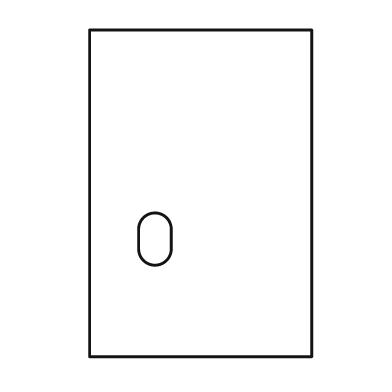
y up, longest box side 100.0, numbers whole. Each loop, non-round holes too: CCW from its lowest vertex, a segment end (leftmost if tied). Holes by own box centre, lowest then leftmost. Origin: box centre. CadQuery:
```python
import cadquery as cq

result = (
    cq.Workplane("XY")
    .moveTo(-34.0, -50.0)
    .lineTo(34.0, -50.0)
    .lineTo(34.0, 50.0)
    .lineTo(-34.0, 50.0)
    .close()
    .moveTo(-19.0, -17.0)
    .threePointArc((-14.0, -22.0), (-9.0, -17.0))
    .lineTo(-9.0, -11.0)
    .threePointArc((-14.0, -6.0), (-19.0, -11.0))
    .close()
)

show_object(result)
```